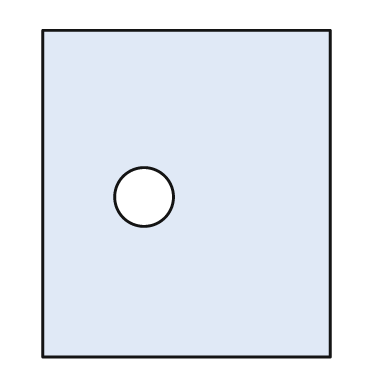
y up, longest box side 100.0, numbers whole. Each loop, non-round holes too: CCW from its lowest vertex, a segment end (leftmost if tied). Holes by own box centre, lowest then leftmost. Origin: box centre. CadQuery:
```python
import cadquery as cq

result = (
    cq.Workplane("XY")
    .moveTo(-44.0, -50.0)
    .lineTo(44.0, -50.0)
    .lineTo(44.0, 50.0)
    .lineTo(-44.0, 50.0)
    .close()
    .moveTo(-13.0, -1.0)
    .circle(9.0)
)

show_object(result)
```